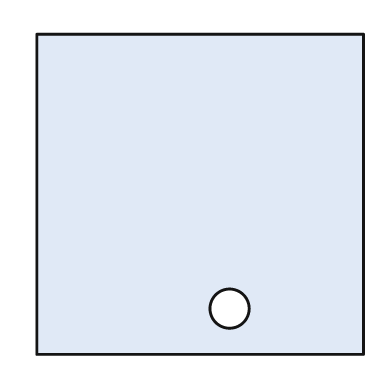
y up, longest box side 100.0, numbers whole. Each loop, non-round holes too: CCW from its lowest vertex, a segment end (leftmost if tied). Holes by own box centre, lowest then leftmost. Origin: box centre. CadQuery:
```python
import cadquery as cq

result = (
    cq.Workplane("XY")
    .moveTo(-50.0, -49.0)
    .lineTo(50.0, -49.0)
    .lineTo(50.0, 49.0)
    .lineTo(-50.0, 49.0)
    .close()
    .moveTo(9.0, -35.0)
    .circle(6.0)
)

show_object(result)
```